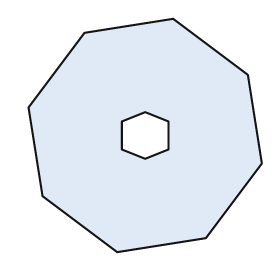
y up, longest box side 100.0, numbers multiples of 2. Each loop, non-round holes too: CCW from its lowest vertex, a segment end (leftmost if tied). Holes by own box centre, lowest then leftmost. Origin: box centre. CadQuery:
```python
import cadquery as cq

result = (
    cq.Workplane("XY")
    .moveTo(-12.0, -50.0)
    .lineTo(26.0, -44.0)
    .lineTo(50.0, -12.0)
    .lineTo(44.0, 26.0)
    .lineTo(12.0, 50.0)
    .lineTo(-26.0, 44.0)
    .lineTo(-50.0, 12.0)
    .lineTo(-44.0, -26.0)
    .close()
    .moveTo(0.0, -10.0)
    .lineTo(10.0, -6.0)
    .lineTo(10.0, 6.0)
    .lineTo(0.0, 10.0)
    .lineTo(-10.0, 6.0)
    .lineTo(-10.0, -6.0)
    .close()
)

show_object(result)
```